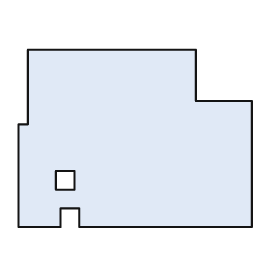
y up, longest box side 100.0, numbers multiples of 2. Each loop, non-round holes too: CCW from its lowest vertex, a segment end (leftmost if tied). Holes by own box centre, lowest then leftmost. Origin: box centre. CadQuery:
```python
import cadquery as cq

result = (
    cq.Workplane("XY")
    .moveTo(-50.0, -38.0)
    .lineTo(-32.0, -38.0)
    .lineTo(-32.0, -30.0)
    .lineTo(-24.0, -30.0)
    .lineTo(-24.0, -38.0)
    .lineTo(50.0, -38.0)
    .lineTo(50.0, 16.0)
    .lineTo(26.0, 16.0)
    .lineTo(26.0, 38.0)
    .lineTo(-46.0, 38.0)
    .lineTo(-46.0, 6.0)
    .lineTo(-50.0, 6.0)
    .close()
    .moveTo(-34.0, -22.0)
    .lineTo(-26.0, -22.0)
    .lineTo(-26.0, -14.0)
    .lineTo(-34.0, -14.0)
    .close()
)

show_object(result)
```